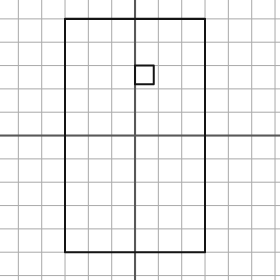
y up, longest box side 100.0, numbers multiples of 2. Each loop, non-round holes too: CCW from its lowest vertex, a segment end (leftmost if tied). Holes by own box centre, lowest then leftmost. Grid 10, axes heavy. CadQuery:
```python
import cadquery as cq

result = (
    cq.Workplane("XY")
    .moveTo(-30.0, -50.0)
    .lineTo(30.0, -50.0)
    .lineTo(30.0, 50.0)
    .lineTo(-30.0, 50.0)
    .close()
    .moveTo(0.0, 22.0)
    .lineTo(8.0, 22.0)
    .lineTo(8.0, 30.0)
    .lineTo(0.0, 30.0)
    .close()
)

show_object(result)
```